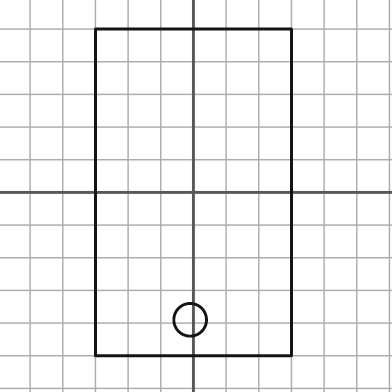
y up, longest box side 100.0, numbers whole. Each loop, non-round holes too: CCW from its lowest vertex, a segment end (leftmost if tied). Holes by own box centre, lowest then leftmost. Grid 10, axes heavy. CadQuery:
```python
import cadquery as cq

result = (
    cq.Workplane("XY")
    .moveTo(-30.0, -50.0)
    .lineTo(30.0, -50.0)
    .lineTo(30.0, 50.0)
    .lineTo(-30.0, 50.0)
    .close()
    .moveTo(-1.0, -39.0)
    .circle(5.0)
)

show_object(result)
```